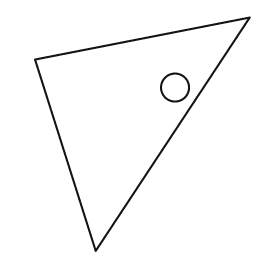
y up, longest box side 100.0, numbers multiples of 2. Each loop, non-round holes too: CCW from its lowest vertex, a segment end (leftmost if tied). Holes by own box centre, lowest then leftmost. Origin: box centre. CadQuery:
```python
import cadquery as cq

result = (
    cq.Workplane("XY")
    .moveTo(-20.0, -50.0)
    .lineTo(46.0, 50.0)
    .lineTo(-46.0, 32.0)
    .close()
    .moveTo(14.0, 20.0)
    .circle(6.0)
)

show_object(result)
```